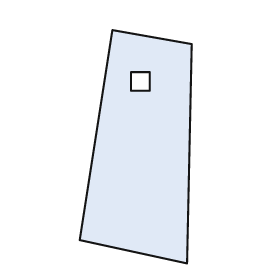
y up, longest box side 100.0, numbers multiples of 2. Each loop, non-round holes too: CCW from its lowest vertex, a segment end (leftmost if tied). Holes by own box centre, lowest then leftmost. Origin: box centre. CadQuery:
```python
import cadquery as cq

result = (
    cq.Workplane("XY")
    .moveTo(22.0, -50.0)
    .lineTo(24.0, 44.0)
    .lineTo(-10.0, 50.0)
    .lineTo(-24.0, -40.0)
    .close()
    .moveTo(-2.0, 24.0)
    .lineTo(6.0, 24.0)
    .lineTo(6.0, 32.0)
    .lineTo(-2.0, 32.0)
    .close()
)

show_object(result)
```